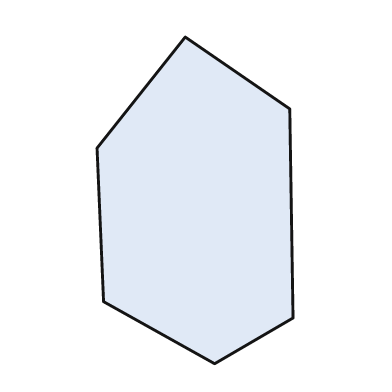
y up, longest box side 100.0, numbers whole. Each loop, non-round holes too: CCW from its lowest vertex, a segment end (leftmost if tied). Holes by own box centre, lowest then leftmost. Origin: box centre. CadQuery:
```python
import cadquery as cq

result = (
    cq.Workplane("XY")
    .moveTo(6.0, -50.0)
    .lineTo(30.0, -36.0)
    .lineTo(29.0, 28.0)
    .lineTo(-3.0, 50.0)
    .lineTo(-30.0, 16.0)
    .lineTo(-28.0, -31.0)
    .close()
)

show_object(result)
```